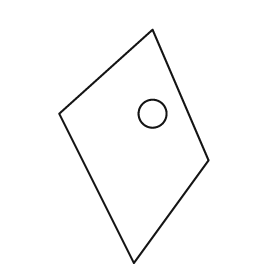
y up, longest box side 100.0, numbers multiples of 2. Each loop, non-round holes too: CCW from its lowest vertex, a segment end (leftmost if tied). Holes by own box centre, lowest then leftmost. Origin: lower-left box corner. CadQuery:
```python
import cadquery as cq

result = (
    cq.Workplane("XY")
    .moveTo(32.0, 0.0)
    .lineTo(64.0, 44.0)
    .lineTo(40.0, 100.0)
    .lineTo(0.0, 64.0)
    .close()
    .moveTo(40.0, 64.0)
    .circle(6.0)
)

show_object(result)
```